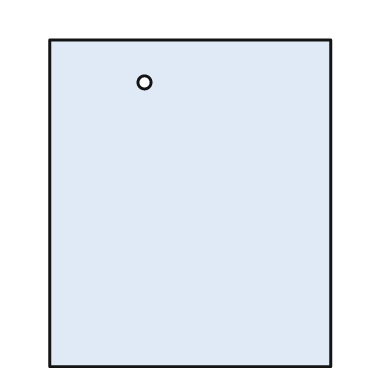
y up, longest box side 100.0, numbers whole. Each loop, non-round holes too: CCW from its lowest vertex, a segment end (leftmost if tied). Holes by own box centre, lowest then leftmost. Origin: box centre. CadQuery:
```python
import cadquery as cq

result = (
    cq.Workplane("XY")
    .moveTo(-43.0, -50.0)
    .lineTo(43.0, -50.0)
    .lineTo(43.0, 50.0)
    .lineTo(-43.0, 50.0)
    .close()
    .moveTo(-14.0, 37.0)
    .circle(2.0)
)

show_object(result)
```